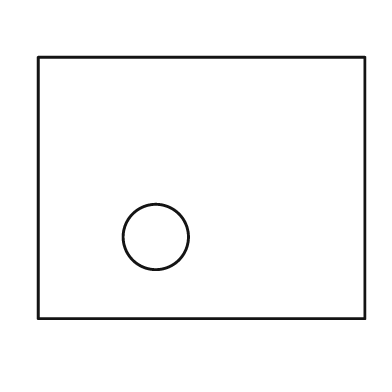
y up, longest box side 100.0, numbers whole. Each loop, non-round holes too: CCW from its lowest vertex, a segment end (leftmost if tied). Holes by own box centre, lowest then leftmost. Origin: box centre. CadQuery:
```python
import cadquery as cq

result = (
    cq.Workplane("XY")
    .moveTo(-50.0, -40.0)
    .lineTo(50.0, -40.0)
    .lineTo(50.0, 40.0)
    .lineTo(-50.0, 40.0)
    .close()
    .moveTo(-14.0, -15.0)
    .circle(10.0)
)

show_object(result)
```